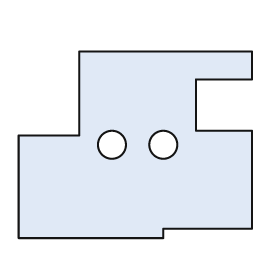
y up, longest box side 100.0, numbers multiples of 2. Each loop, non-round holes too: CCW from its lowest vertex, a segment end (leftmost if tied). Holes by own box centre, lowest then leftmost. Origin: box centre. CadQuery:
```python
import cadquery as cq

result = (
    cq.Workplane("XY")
    .moveTo(-50.0, -40.0)
    .lineTo(12.0, -40.0)
    .lineTo(12.0, -36.0)
    .lineTo(50.0, -36.0)
    .lineTo(50.0, 6.0)
    .lineTo(26.0, 6.0)
    .lineTo(26.0, 28.0)
    .lineTo(50.0, 28.0)
    .lineTo(50.0, 40.0)
    .lineTo(-24.0, 40.0)
    .lineTo(-24.0, 4.0)
    .lineTo(-50.0, 4.0)
    .close()
    .moveTo(-10.0, 0.0)
    .circle(6.0)
    .moveTo(12.0, 0.0)
    .circle(6.0)
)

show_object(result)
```